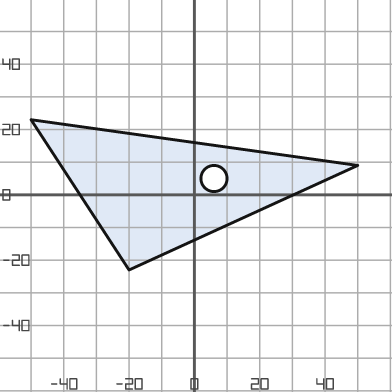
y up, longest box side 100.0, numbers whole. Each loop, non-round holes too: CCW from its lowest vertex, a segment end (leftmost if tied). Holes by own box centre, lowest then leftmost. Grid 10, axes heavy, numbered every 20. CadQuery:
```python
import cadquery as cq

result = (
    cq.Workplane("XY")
    .moveTo(-20.0, -23.0)
    .lineTo(50.0, 9.0)
    .lineTo(-50.0, 23.0)
    .close()
    .moveTo(6.0, 5.0)
    .circle(4.0)
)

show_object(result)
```